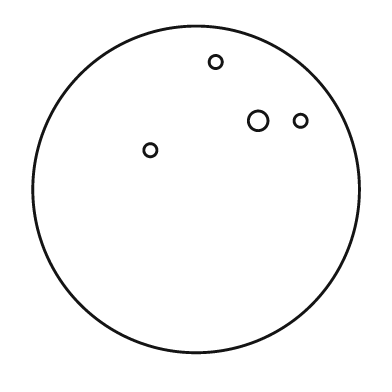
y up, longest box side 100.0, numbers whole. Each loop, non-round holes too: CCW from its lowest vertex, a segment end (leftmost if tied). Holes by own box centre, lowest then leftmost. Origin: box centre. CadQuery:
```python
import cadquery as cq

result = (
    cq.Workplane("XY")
    .moveTo(0.0, 0.0)
    .circle(50.0)
    .moveTo(-14.0, 12.0)
    .circle(2.0)
    .moveTo(19.0, 21.0)
    .circle(3.0)
    .moveTo(32.0, 21.0)
    .circle(2.0)
    .moveTo(6.0, 39.0)
    .circle(2.0)
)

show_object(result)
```